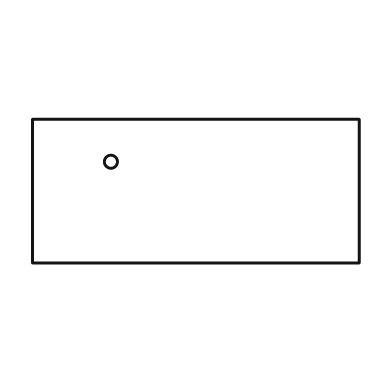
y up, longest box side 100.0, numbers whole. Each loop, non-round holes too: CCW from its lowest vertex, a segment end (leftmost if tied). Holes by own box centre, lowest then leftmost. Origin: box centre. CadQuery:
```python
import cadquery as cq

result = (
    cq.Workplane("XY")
    .moveTo(-50.0, -22.0)
    .lineTo(50.0, -22.0)
    .lineTo(50.0, 22.0)
    .lineTo(-50.0, 22.0)
    .close()
    .moveTo(-26.0, 9.0)
    .circle(2.0)
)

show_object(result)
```